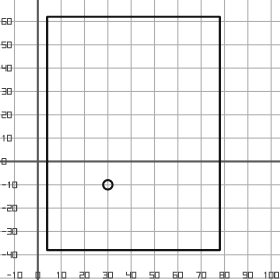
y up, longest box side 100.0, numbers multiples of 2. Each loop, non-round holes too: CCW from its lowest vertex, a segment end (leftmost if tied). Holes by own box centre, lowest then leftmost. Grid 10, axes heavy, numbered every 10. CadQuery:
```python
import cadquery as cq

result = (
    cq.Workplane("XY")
    .moveTo(4.0, -38.0)
    .lineTo(78.0, -38.0)
    .lineTo(78.0, 62.0)
    .lineTo(4.0, 62.0)
    .close()
    .moveTo(30.0, -10.0)
    .circle(2.0)
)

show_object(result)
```